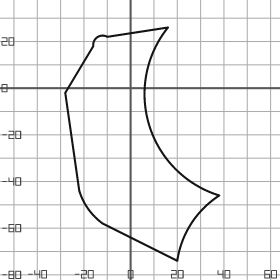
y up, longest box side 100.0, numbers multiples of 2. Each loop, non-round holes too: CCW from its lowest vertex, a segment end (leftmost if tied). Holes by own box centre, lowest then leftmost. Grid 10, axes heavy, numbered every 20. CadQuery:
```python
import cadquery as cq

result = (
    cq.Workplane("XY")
    .moveTo(20.0, -74.0)
    .threePointArc((26.0, -58.0), (38.0, -46.0))
    .threePointArc((8.0, -16.0), (16.0, 26.0))
    .lineTo(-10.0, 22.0)
    .threePointArc((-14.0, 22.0), (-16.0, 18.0))
    .lineTo(-28.0, -2.0)
    .lineTo(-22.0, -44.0)
    .threePointArc((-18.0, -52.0), (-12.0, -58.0))
    .close()
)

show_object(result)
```